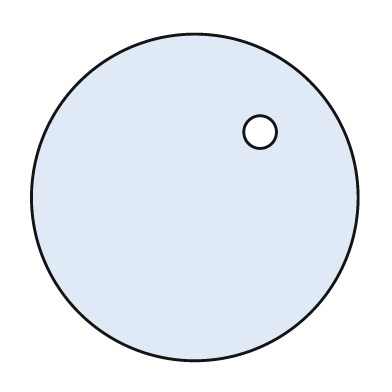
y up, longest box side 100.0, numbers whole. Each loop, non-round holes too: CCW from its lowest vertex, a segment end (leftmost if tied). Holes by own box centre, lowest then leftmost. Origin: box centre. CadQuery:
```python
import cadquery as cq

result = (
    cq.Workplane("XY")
    .moveTo(0.0, 0.0)
    .circle(50.0)
    .moveTo(20.0, 20.0)
    .circle(5.0)
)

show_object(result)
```